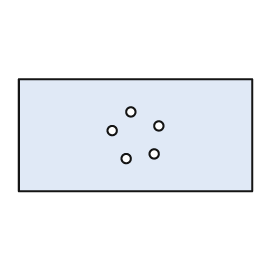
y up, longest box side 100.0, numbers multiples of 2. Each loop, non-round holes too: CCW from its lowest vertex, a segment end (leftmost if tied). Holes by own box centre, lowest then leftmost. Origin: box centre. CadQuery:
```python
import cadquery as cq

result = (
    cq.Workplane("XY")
    .moveTo(-50.0, -24.0)
    .lineTo(50.0, -24.0)
    .lineTo(50.0, 24.0)
    .lineTo(-50.0, 24.0)
    .close()
    .moveTo(-4.0, -10.0)
    .circle(2.0)
    .moveTo(8.0, -8.0)
    .circle(2.0)
    .moveTo(-10.0, 2.0)
    .circle(2.0)
    .moveTo(10.0, 4.0)
    .circle(2.0)
    .moveTo(-2.0, 10.0)
    .circle(2.0)
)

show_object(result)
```